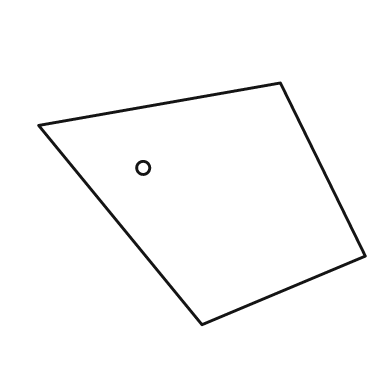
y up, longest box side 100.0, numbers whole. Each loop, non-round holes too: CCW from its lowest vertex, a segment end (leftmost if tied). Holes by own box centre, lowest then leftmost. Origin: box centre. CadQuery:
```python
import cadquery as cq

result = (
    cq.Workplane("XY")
    .moveTo(0.0, -37.0)
    .lineTo(50.0, -16.0)
    .lineTo(24.0, 37.0)
    .lineTo(-50.0, 24.0)
    .close()
    .moveTo(-18.0, 11.0)
    .circle(2.0)
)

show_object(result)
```